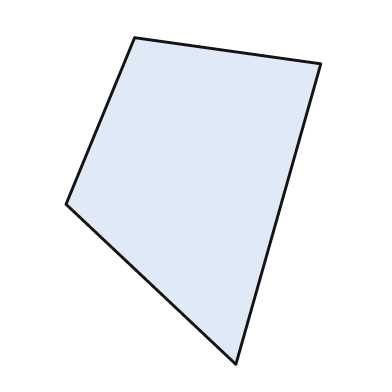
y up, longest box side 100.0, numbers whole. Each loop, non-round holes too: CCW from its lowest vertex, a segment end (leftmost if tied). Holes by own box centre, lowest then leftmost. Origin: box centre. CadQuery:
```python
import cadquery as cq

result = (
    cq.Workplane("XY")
    .moveTo(13.0, -50.0)
    .lineTo(39.0, 42.0)
    .lineTo(-18.0, 50.0)
    .lineTo(-39.0, -1.0)
    .close()
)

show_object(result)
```